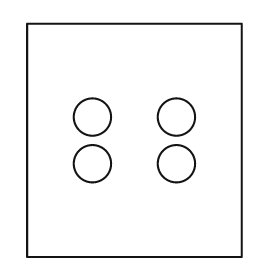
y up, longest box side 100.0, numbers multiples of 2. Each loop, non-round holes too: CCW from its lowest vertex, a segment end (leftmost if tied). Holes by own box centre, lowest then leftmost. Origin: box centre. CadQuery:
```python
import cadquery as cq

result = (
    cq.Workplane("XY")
    .moveTo(-46.0, -50.0)
    .lineTo(46.0, -50.0)
    .lineTo(46.0, 50.0)
    .lineTo(-46.0, 50.0)
    .close()
    .moveTo(-18.0, -10.0)
    .circle(8.0)
    .moveTo(18.0, -10.0)
    .circle(8.0)
    .moveTo(-18.0, 10.0)
    .circle(8.0)
    .moveTo(18.0, 10.0)
    .circle(8.0)
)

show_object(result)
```